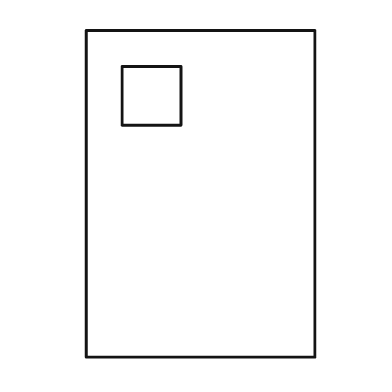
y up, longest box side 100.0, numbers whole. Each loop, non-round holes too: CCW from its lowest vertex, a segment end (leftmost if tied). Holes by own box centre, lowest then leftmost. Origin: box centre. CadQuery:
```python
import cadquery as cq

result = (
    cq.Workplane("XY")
    .moveTo(-35.0, -50.0)
    .lineTo(35.0, -50.0)
    .lineTo(35.0, 50.0)
    .lineTo(-35.0, 50.0)
    .close()
    .moveTo(-24.0, 21.0)
    .lineTo(-6.0, 21.0)
    .lineTo(-6.0, 39.0)
    .lineTo(-24.0, 39.0)
    .close()
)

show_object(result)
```